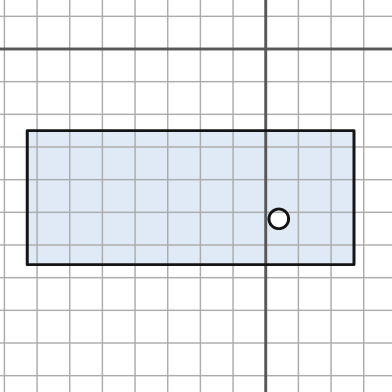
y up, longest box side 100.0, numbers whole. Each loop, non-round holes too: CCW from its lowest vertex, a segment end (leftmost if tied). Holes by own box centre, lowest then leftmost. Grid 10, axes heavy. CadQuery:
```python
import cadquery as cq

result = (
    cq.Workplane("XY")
    .moveTo(-73.0, -66.0)
    .lineTo(27.0, -66.0)
    .lineTo(27.0, -25.0)
    .lineTo(-73.0, -25.0)
    .close()
    .moveTo(4.0, -52.0)
    .circle(3.0)
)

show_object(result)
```